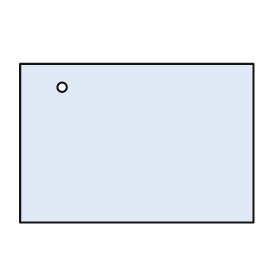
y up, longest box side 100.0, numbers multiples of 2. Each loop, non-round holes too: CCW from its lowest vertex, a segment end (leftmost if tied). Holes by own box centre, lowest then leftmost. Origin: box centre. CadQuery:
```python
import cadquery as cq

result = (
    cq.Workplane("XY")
    .moveTo(-50.0, -34.0)
    .lineTo(50.0, -34.0)
    .lineTo(50.0, 34.0)
    .lineTo(-50.0, 34.0)
    .close()
    .moveTo(-32.0, 24.0)
    .circle(2.0)
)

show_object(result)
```